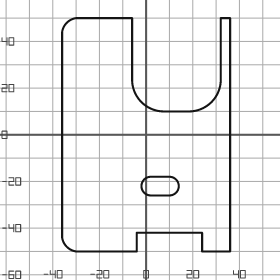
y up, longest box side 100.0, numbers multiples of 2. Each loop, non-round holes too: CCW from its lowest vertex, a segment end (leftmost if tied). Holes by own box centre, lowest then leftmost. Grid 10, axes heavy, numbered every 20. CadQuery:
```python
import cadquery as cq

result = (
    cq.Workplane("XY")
    .moveTo(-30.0, -50.0)
    .lineTo(-4.0, -50.0)
    .lineTo(-4.0, -42.0)
    .lineTo(24.0, -42.0)
    .lineTo(24.0, -50.0)
    .lineTo(36.0, -50.0)
    .lineTo(36.0, 50.0)
    .lineTo(32.0, 50.0)
    .lineTo(32.0, 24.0)
    .threePointArc((28.0, 14.0), (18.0, 10.0))
    .lineTo(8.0, 10.0)
    .threePointArc((-2.0, 14.0), (-6.0, 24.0))
    .lineTo(-6.0, 50.0)
    .lineTo(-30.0, 50.0)
    .threePointArc((-34.0, 48.0), (-36.0, 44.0))
    .lineTo(-36.0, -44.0)
    .threePointArc((-34.0, -48.0), (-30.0, -50.0))
    .close()
    .moveTo(2.0, -26.0)
    .lineTo(10.0, -26.0)
    .threePointArc((14.0, -22.0), (10.0, -18.0))
    .lineTo(2.0, -18.0)
    .threePointArc((-2.0, -22.0), (2.0, -26.0))
    .close()
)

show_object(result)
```